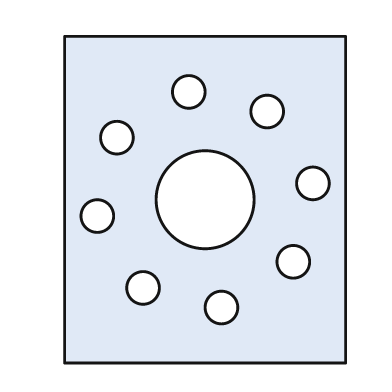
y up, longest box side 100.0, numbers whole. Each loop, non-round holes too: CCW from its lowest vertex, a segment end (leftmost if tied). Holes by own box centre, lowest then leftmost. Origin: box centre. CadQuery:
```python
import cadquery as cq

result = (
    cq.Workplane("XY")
    .moveTo(-43.0, -50.0)
    .lineTo(43.0, -50.0)
    .lineTo(43.0, 50.0)
    .lineTo(-43.0, 50.0)
    .close()
    .moveTo(5.0, -33.0)
    .circle(5.0)
    .moveTo(-19.0, -27.0)
    .circle(5.0)
    .moveTo(27.0, -19.0)
    .circle(5.0)
    .moveTo(-33.0, -5.0)
    .circle(5.0)
    .moveTo(0.0, 0.0)
    .circle(15.0)
    .moveTo(33.0, 5.0)
    .circle(5.0)
    .moveTo(-27.0, 19.0)
    .circle(5.0)
    .moveTo(19.0, 27.0)
    .circle(5.0)
    .moveTo(-5.0, 33.0)
    .circle(5.0)
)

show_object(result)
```